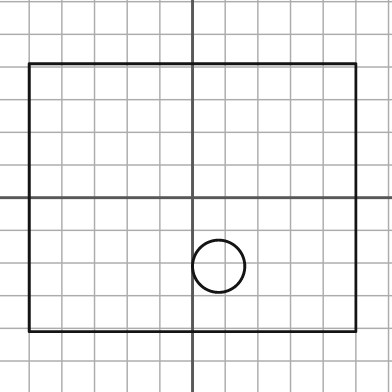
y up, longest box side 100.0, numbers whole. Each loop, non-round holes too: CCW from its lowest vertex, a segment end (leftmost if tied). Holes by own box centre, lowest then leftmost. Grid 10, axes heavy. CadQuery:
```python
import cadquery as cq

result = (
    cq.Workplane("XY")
    .moveTo(-50.0, -41.0)
    .lineTo(50.0, -41.0)
    .lineTo(50.0, 41.0)
    .lineTo(-50.0, 41.0)
    .close()
    .moveTo(8.0, -21.0)
    .circle(8.0)
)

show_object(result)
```